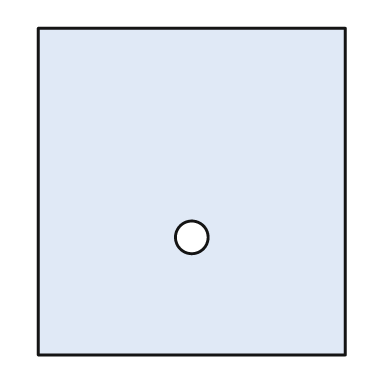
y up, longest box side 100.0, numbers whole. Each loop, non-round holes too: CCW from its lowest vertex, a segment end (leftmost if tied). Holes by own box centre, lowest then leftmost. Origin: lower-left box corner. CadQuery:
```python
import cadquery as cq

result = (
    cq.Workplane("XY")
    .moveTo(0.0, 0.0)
    .lineTo(94.0, 0.0)
    .lineTo(94.0, 100.0)
    .lineTo(0.0, 100.0)
    .close()
    .moveTo(47.0, 36.0)
    .circle(5.0)
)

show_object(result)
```